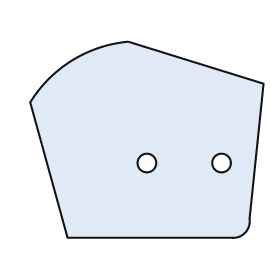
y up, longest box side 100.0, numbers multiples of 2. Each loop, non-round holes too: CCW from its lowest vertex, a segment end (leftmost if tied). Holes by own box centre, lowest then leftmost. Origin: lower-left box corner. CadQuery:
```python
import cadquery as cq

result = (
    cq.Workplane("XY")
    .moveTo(16.0, 0.0)
    .lineTo(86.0, 0.0)
    .threePointArc((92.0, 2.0), (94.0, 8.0))
    .lineTo(100.0, 66.0)
    .lineTo(42.0, 84.0)
    .threePointArc((18.0, 76.0), (0.0, 58.0))
    .close()
    .moveTo(50.0, 32.0)
    .circle(4.0)
    .moveTo(82.0, 32.0)
    .circle(4.0)
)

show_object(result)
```